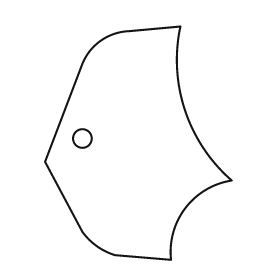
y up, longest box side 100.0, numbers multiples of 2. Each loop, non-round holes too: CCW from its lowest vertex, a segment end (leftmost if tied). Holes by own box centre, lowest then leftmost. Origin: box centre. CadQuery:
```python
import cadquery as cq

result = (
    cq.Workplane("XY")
    .moveTo(14.0, -50.0)
    .threePointArc((20.0, -28.0), (40.0, -16.0))
    .threePointArc((20.0, 14.0), (18.0, 50.0))
    .lineTo(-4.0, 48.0)
    .threePointArc((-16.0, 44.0), (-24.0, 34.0))
    .lineTo(-40.0, -8.0)
    .lineTo(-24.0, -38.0)
    .threePointArc((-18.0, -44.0), (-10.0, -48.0))
    .close()
    .moveTo(-24.0, 2.0)
    .circle(4.0)
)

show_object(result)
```